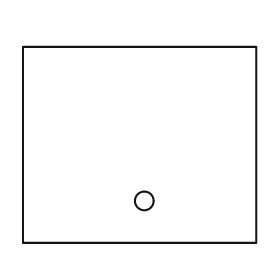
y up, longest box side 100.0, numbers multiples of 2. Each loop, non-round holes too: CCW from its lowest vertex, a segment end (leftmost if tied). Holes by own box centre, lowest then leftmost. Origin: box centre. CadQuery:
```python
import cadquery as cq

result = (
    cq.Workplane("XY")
    .moveTo(-50.0, -42.0)
    .lineTo(50.0, -42.0)
    .lineTo(50.0, 42.0)
    .lineTo(-50.0, 42.0)
    .close()
    .moveTo(2.0, -24.0)
    .circle(4.0)
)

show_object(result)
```